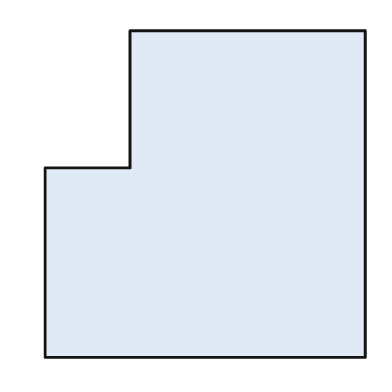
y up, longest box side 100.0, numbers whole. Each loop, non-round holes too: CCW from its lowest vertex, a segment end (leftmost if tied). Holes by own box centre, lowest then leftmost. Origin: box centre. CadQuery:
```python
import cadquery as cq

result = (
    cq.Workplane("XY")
    .moveTo(-49.0, -50.0)
    .lineTo(49.0, -50.0)
    .lineTo(49.0, 50.0)
    .lineTo(-23.0, 50.0)
    .lineTo(-23.0, 8.0)
    .lineTo(-49.0, 8.0)
    .close()
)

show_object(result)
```